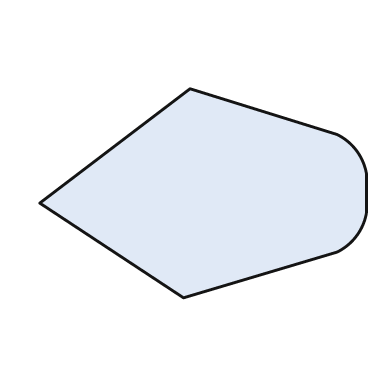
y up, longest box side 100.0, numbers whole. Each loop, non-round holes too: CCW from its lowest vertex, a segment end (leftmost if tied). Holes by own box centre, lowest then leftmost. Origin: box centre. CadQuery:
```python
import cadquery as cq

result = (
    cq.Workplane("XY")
    .moveTo(-6.0, -32.0)
    .lineTo(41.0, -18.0)
    .threePointArc((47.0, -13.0), (50.0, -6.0))
    .lineTo(50.0, 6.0)
    .threePointArc((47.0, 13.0), (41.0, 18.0))
    .lineTo(-4.0, 32.0)
    .lineTo(-50.0, -3.0)
    .close()
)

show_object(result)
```